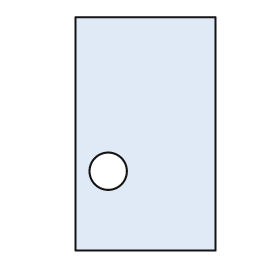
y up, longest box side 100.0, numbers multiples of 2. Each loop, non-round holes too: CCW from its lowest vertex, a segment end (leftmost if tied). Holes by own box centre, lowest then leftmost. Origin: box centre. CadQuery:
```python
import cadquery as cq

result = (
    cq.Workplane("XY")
    .moveTo(-30.0, -50.0)
    .lineTo(30.0, -50.0)
    .lineTo(30.0, 50.0)
    .lineTo(-30.0, 50.0)
    .close()
    .moveTo(-16.0, -16.0)
    .circle(8.0)
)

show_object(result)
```